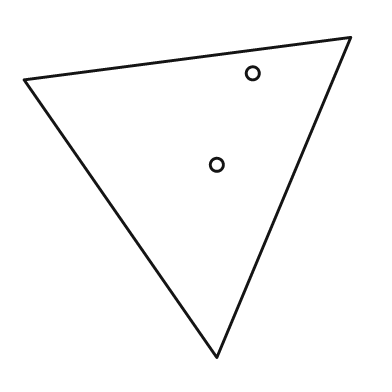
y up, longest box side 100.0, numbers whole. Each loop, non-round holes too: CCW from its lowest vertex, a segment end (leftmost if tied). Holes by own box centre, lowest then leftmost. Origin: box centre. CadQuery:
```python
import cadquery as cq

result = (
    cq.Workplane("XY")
    .moveTo(9.0, -49.0)
    .lineTo(50.0, 49.0)
    .lineTo(-50.0, 36.0)
    .close()
    .moveTo(9.0, 10.0)
    .circle(2.0)
    .moveTo(20.0, 38.0)
    .circle(2.0)
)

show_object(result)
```